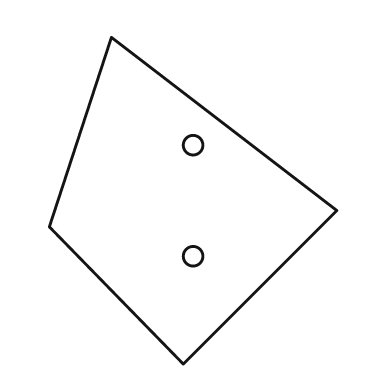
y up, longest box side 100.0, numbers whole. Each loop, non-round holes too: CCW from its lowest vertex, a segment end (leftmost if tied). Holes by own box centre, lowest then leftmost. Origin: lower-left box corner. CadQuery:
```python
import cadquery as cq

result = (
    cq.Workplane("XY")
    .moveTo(41.0, 0.0)
    .lineTo(88.0, 47.0)
    .lineTo(19.0, 100.0)
    .lineTo(0.0, 42.0)
    .close()
    .moveTo(44.0, 33.0)
    .circle(3.0)
    .moveTo(44.0, 67.0)
    .circle(3.0)
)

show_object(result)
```